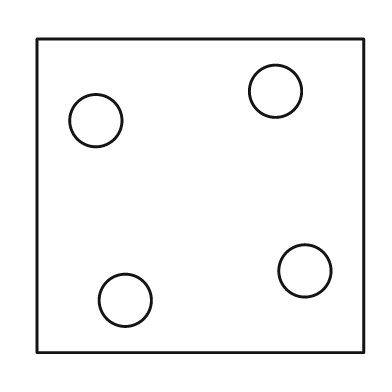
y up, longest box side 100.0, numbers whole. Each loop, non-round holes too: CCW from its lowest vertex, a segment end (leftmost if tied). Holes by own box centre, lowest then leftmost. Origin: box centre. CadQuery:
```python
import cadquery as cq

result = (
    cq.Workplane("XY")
    .moveTo(-50.0, -48.0)
    .lineTo(50.0, -48.0)
    .lineTo(50.0, 48.0)
    .lineTo(-50.0, 48.0)
    .close()
    .moveTo(-23.0, -32.0)
    .circle(8.0)
    .moveTo(32.0, -23.0)
    .circle(8.0)
    .moveTo(-32.0, 23.0)
    .circle(8.0)
    .moveTo(23.0, 32.0)
    .circle(8.0)
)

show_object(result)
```